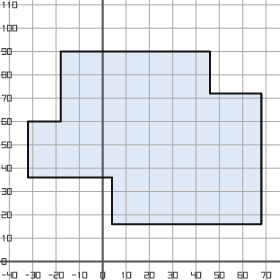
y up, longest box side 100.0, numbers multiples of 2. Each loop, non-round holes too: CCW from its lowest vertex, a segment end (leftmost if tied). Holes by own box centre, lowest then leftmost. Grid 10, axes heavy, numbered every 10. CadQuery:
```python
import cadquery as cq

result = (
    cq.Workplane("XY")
    .moveTo(4.0, 16.0)
    .lineTo(68.0, 16.0)
    .lineTo(68.0, 72.0)
    .lineTo(46.0, 72.0)
    .lineTo(46.0, 90.0)
    .lineTo(-18.0, 90.0)
    .lineTo(-18.0, 60.0)
    .lineTo(-32.0, 60.0)
    .lineTo(-32.0, 36.0)
    .lineTo(4.0, 36.0)
    .close()
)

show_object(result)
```